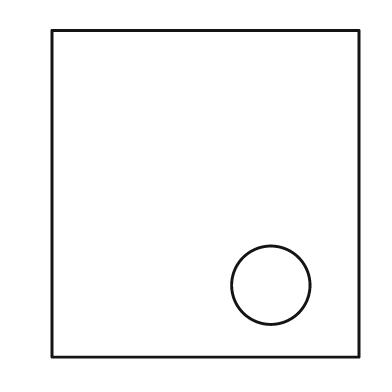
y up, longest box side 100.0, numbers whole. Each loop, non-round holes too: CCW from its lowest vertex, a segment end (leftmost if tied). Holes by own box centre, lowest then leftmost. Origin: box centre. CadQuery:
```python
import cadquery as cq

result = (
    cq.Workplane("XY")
    .moveTo(-47.0, -50.0)
    .lineTo(47.0, -50.0)
    .lineTo(47.0, 50.0)
    .lineTo(-47.0, 50.0)
    .close()
    .moveTo(20.0, -28.0)
    .circle(12.0)
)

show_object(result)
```